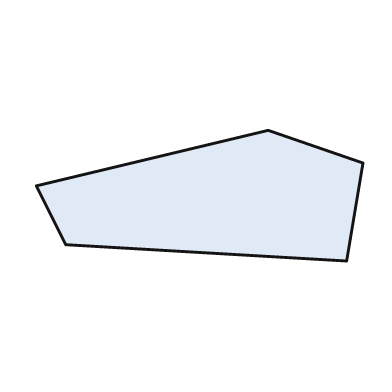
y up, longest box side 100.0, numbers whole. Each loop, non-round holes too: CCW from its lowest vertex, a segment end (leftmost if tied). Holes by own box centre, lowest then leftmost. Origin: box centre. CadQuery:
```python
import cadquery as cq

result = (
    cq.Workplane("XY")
    .moveTo(45.0, -20.0)
    .lineTo(50.0, 10.0)
    .lineTo(21.0, 20.0)
    .lineTo(-50.0, 3.0)
    .lineTo(-41.0, -15.0)
    .close()
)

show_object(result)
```